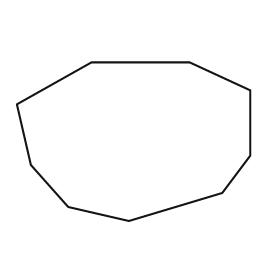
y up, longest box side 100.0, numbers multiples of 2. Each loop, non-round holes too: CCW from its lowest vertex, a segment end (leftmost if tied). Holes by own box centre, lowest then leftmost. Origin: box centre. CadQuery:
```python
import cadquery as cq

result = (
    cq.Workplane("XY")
    .moveTo(-2.0, -34.0)
    .lineTo(38.0, -22.0)
    .lineTo(50.0, -6.0)
    .lineTo(50.0, 22.0)
    .lineTo(24.0, 34.0)
    .lineTo(-18.0, 34.0)
    .lineTo(-50.0, 16.0)
    .lineTo(-44.0, -10.0)
    .lineTo(-28.0, -28.0)
    .close()
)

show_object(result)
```